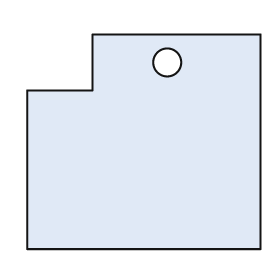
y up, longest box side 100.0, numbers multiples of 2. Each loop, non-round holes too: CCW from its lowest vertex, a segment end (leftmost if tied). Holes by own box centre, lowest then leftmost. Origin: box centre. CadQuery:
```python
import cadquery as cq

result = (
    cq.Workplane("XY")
    .moveTo(-50.0, -46.0)
    .lineTo(50.0, -46.0)
    .lineTo(50.0, 46.0)
    .lineTo(-22.0, 46.0)
    .lineTo(-22.0, 22.0)
    .lineTo(-50.0, 22.0)
    .close()
    .moveTo(10.0, 34.0)
    .circle(6.0)
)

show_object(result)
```